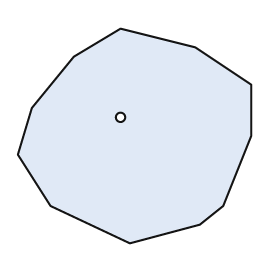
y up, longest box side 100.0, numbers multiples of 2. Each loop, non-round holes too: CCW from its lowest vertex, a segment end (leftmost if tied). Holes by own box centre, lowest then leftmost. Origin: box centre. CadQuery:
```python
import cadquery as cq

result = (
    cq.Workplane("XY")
    .moveTo(-2.0, -46.0)
    .lineTo(28.0, -38.0)
    .lineTo(38.0, -30.0)
    .lineTo(50.0, 0.0)
    .lineTo(50.0, 22.0)
    .lineTo(26.0, 38.0)
    .lineTo(-6.0, 46.0)
    .lineTo(-26.0, 34.0)
    .lineTo(-44.0, 12.0)
    .lineTo(-50.0, -8.0)
    .lineTo(-36.0, -30.0)
    .close()
    .moveTo(-6.0, 8.0)
    .circle(2.0)
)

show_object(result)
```